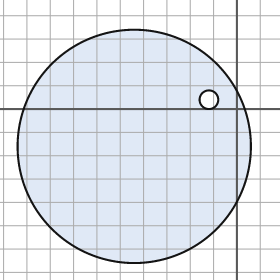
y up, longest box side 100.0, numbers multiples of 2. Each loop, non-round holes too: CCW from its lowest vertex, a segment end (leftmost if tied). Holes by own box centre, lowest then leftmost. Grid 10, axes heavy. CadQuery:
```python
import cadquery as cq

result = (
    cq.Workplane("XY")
    .moveTo(-44.0, -16.0)
    .circle(50.0)
    .moveTo(-12.0, 4.0)
    .circle(4.0)
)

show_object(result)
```